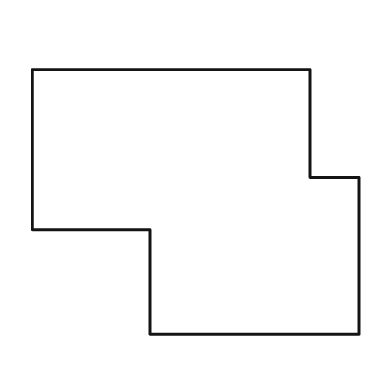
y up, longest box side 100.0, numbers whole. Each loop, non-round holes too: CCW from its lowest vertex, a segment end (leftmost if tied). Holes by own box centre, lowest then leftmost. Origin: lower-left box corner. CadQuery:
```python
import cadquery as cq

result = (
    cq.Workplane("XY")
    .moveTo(36.0, 0.0)
    .lineTo(100.0, 0.0)
    .lineTo(100.0, 48.0)
    .lineTo(85.0, 48.0)
    .lineTo(85.0, 81.0)
    .lineTo(0.0, 81.0)
    .lineTo(0.0, 32.0)
    .lineTo(36.0, 32.0)
    .close()
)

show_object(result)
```